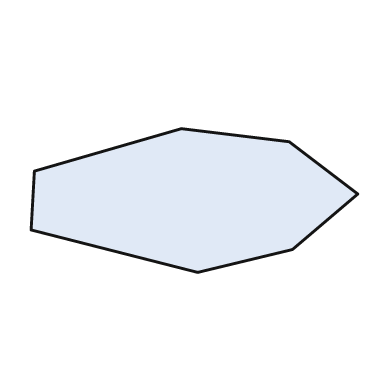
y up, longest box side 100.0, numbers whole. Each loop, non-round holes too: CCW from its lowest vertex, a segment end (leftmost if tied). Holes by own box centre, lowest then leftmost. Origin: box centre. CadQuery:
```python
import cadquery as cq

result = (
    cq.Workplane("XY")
    .moveTo(1.0, -22.0)
    .lineTo(30.0, -15.0)
    .lineTo(50.0, 2.0)
    .lineTo(29.0, 18.0)
    .lineTo(-4.0, 22.0)
    .lineTo(-49.0, 9.0)
    .lineTo(-50.0, -9.0)
    .close()
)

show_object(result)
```